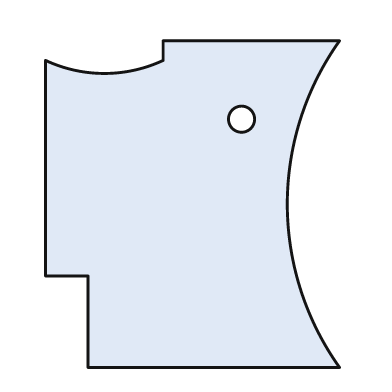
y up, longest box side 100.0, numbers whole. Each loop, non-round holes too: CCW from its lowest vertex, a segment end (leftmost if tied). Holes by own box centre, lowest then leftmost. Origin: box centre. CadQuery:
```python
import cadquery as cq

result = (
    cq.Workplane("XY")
    .moveTo(-32.0, -50.0)
    .lineTo(45.0, -50.0)
    .threePointArc((29.0, 0.0), (45.0, 50.0))
    .lineTo(-9.0, 50.0)
    .lineTo(-9.0, 44.0)
    .threePointArc((-27.0, 40.0), (-45.0, 44.0))
    .lineTo(-45.0, -22.0)
    .lineTo(-32.0, -22.0)
    .close()
    .moveTo(15.0, 26.0)
    .circle(4.0)
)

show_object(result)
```